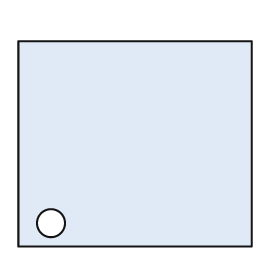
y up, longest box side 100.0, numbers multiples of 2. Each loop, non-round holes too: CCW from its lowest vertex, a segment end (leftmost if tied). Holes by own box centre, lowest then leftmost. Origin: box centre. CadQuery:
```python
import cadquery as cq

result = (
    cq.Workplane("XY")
    .moveTo(-50.0, -44.0)
    .lineTo(50.0, -44.0)
    .lineTo(50.0, 44.0)
    .lineTo(-50.0, 44.0)
    .close()
    .moveTo(-36.0, -34.0)
    .circle(6.0)
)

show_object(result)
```